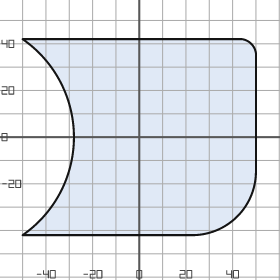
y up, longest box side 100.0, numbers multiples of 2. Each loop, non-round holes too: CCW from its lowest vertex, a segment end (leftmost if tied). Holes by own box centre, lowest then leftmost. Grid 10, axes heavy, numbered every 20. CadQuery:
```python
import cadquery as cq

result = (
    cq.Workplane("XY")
    .moveTo(-50.0, -42.0)
    .lineTo(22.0, -42.0)
    .threePointArc((42.0, -34.0), (50.0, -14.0))
    .lineTo(50.0, 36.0)
    .threePointArc((48.0, 40.0), (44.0, 42.0))
    .lineTo(-50.0, 42.0)
    .threePointArc((-28.0, 0.0), (-50.0, -42.0))
    .close()
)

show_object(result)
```